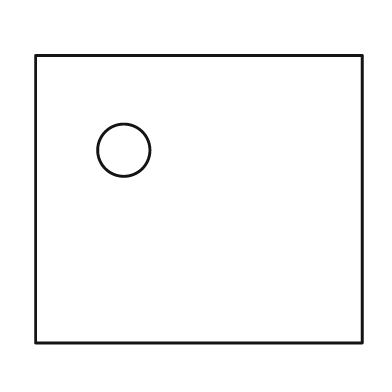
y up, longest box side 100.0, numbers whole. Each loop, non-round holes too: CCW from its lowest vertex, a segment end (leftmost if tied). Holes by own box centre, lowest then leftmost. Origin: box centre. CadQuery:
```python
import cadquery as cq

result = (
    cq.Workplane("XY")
    .moveTo(-50.0, -44.0)
    .lineTo(50.0, -44.0)
    .lineTo(50.0, 44.0)
    .lineTo(-50.0, 44.0)
    .close()
    .moveTo(-23.0, 15.0)
    .circle(8.0)
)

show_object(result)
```